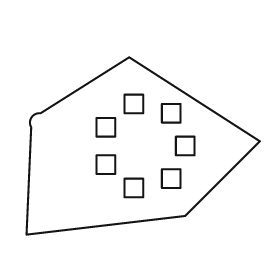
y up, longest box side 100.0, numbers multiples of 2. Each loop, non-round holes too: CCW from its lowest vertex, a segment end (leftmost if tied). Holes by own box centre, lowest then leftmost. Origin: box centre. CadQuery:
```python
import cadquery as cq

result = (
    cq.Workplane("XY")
    .moveTo(-50.0, -38.0)
    .lineTo(18.0, -30.0)
    .lineTo(50.0, 2.0)
    .lineTo(-6.0, 38.0)
    .lineTo(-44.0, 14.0)
    .threePointArc((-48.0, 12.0), (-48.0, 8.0))
    .close()
    .moveTo(-8.0, -22.0)
    .lineTo(0.0, -22.0)
    .lineTo(0.0, -14.0)
    .lineTo(-8.0, -14.0)
    .close()
    .moveTo(8.0, -18.0)
    .lineTo(16.0, -18.0)
    .lineTo(16.0, -10.0)
    .lineTo(8.0, -10.0)
    .close()
    .moveTo(-20.0, -12.0)
    .lineTo(-12.0, -12.0)
    .lineTo(-12.0, -4.0)
    .lineTo(-20.0, -4.0)
    .close()
    .moveTo(14.0, -4.0)
    .lineTo(22.0, -4.0)
    .lineTo(22.0, 4.0)
    .lineTo(14.0, 4.0)
    .close()
    .moveTo(-20.0, 4.0)
    .lineTo(-12.0, 4.0)
    .lineTo(-12.0, 12.0)
    .lineTo(-20.0, 12.0)
    .close()
    .moveTo(8.0, 10.0)
    .lineTo(16.0, 10.0)
    .lineTo(16.0, 18.0)
    .lineTo(8.0, 18.0)
    .close()
    .moveTo(-8.0, 14.0)
    .lineTo(0.0, 14.0)
    .lineTo(0.0, 22.0)
    .lineTo(-8.0, 22.0)
    .close()
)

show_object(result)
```